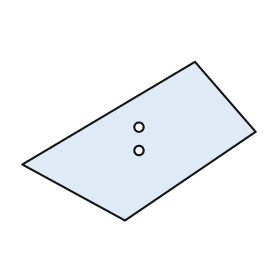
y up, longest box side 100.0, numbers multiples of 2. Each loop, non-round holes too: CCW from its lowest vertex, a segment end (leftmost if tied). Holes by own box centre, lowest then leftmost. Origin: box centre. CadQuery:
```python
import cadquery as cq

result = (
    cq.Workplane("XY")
    .moveTo(-6.0, -34.0)
    .lineTo(50.0, 4.0)
    .lineTo(24.0, 34.0)
    .lineTo(-50.0, -10.0)
    .close()
    .moveTo(0.0, -4.0)
    .circle(2.0)
    .moveTo(0.0, 6.0)
    .circle(2.0)
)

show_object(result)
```